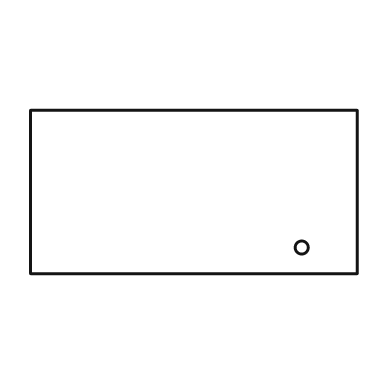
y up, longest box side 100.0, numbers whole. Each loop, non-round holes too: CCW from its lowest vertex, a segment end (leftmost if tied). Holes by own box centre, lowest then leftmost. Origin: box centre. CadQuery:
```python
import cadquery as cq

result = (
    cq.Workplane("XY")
    .moveTo(-50.0, -25.0)
    .lineTo(50.0, -25.0)
    .lineTo(50.0, 25.0)
    .lineTo(-50.0, 25.0)
    .close()
    .moveTo(33.0, -17.0)
    .circle(2.0)
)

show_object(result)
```